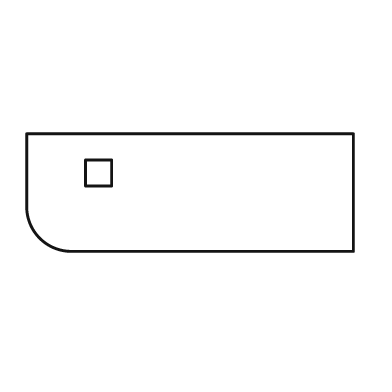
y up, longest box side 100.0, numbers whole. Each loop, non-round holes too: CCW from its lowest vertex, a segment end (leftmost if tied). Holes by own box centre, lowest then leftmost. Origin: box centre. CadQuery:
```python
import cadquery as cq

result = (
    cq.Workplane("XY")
    .moveTo(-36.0, -18.0)
    .lineTo(50.0, -18.0)
    .lineTo(50.0, 18.0)
    .lineTo(-50.0, 18.0)
    .lineTo(-50.0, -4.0)
    .threePointArc((-46.0, -14.0), (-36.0, -18.0))
    .close()
    .moveTo(-32.0, 2.0)
    .lineTo(-24.0, 2.0)
    .lineTo(-24.0, 10.0)
    .lineTo(-32.0, 10.0)
    .close()
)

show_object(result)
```